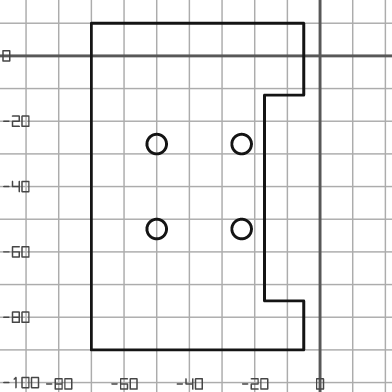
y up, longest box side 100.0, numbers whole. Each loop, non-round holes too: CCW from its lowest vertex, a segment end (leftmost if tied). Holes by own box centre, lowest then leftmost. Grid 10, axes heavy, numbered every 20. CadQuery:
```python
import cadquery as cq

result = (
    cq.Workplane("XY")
    .moveTo(-70.0, -90.0)
    .lineTo(-5.0, -90.0)
    .lineTo(-5.0, -75.0)
    .lineTo(-17.0, -75.0)
    .lineTo(-17.0, -12.0)
    .lineTo(-5.0, -12.0)
    .lineTo(-5.0, 10.0)
    .lineTo(-70.0, 10.0)
    .close()
    .moveTo(-50.0, -53.0)
    .circle(3.0)
    .moveTo(-24.0, -53.0)
    .circle(3.0)
    .moveTo(-50.0, -27.0)
    .circle(3.0)
    .moveTo(-24.0, -27.0)
    .circle(3.0)
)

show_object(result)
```